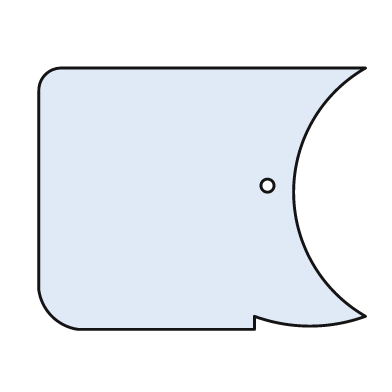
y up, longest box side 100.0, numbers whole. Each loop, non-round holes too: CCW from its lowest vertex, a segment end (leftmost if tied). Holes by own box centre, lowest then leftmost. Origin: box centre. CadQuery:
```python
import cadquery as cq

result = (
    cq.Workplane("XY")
    .moveTo(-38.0, -40.0)
    .lineTo(16.0, -40.0)
    .lineTo(16.0, -36.0)
    .threePointArc((33.0, -39.0), (50.0, -36.0))
    .threePointArc((28.0, 2.0), (50.0, 40.0))
    .lineTo(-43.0, 40.0)
    .threePointArc((-48.0, 38.0), (-50.0, 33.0))
    .lineTo(-50.0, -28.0)
    .threePointArc((-46.0, -36.0), (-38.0, -40.0))
    .close()
    .moveTo(20.0, 4.0)
    .circle(2.0)
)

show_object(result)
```